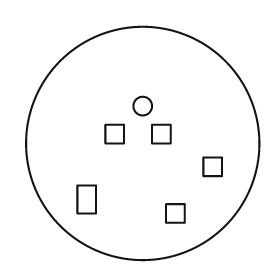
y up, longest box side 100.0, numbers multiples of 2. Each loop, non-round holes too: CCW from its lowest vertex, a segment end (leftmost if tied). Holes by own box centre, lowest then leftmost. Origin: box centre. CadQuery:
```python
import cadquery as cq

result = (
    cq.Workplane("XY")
    .moveTo(0.0, 0.0)
    .circle(50.0)
    .moveTo(10.0, -34.0)
    .lineTo(18.0, -34.0)
    .lineTo(18.0, -26.0)
    .lineTo(10.0, -26.0)
    .close()
    .moveTo(-28.0, -30.0)
    .lineTo(-20.0, -30.0)
    .lineTo(-20.0, -18.0)
    .lineTo(-28.0, -18.0)
    .close()
    .moveTo(26.0, -14.0)
    .lineTo(34.0, -14.0)
    .lineTo(34.0, -6.0)
    .lineTo(26.0, -6.0)
    .close()
    .moveTo(-16.0, 0.0)
    .lineTo(-8.0, 0.0)
    .lineTo(-8.0, 8.0)
    .lineTo(-16.0, 8.0)
    .close()
    .moveTo(4.0, 0.0)
    .lineTo(12.0, 0.0)
    .lineTo(12.0, 8.0)
    .lineTo(4.0, 8.0)
    .close()
    .moveTo(0.0, 16.0)
    .circle(4.0)
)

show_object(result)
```